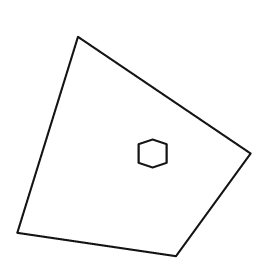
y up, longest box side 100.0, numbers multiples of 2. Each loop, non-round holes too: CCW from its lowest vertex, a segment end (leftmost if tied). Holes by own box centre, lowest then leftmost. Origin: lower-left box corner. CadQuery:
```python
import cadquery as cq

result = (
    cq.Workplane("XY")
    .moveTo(68.0, 0.0)
    .lineTo(100.0, 44.0)
    .lineTo(26.0, 94.0)
    .lineTo(0.0, 10.0)
    .close()
    .moveTo(58.0, 38.0)
    .lineTo(64.0, 40.0)
    .lineTo(64.0, 48.0)
    .lineTo(58.0, 50.0)
    .lineTo(52.0, 48.0)
    .lineTo(52.0, 40.0)
    .close()
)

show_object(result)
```